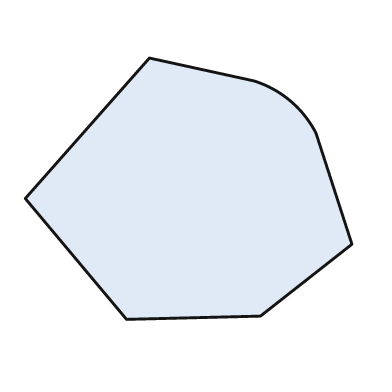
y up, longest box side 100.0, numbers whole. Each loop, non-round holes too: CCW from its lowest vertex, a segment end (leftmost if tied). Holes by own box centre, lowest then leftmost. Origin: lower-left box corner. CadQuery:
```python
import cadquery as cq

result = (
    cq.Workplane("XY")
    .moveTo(31.0, 0.0)
    .lineTo(72.0, 1.0)
    .lineTo(100.0, 23.0)
    .lineTo(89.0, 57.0)
    .threePointArc((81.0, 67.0), (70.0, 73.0))
    .lineTo(38.0, 80.0)
    .lineTo(0.0, 37.0)
    .close()
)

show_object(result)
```